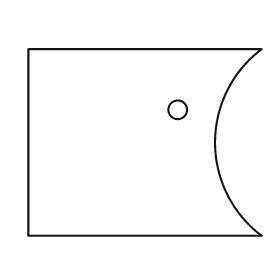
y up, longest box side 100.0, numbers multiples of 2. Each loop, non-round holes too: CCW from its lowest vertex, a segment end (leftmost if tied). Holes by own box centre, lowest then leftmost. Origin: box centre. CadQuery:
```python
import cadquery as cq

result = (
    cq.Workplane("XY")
    .moveTo(-50.0, -40.0)
    .lineTo(50.0, -40.0)
    .threePointArc((30.0, 0.0), (50.0, 40.0))
    .lineTo(-50.0, 40.0)
    .close()
    .moveTo(14.0, 14.0)
    .circle(4.0)
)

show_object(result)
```